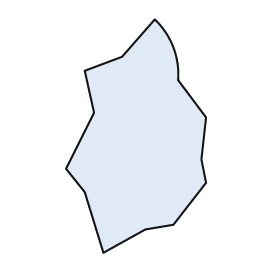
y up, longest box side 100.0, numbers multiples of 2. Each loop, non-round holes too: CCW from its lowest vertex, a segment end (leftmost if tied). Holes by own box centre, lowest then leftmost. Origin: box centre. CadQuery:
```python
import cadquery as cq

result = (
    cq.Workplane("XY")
    .moveTo(-14.0, -50.0)
    .lineTo(4.0, -40.0)
    .lineTo(16.0, -38.0)
    .lineTo(30.0, -20.0)
    .lineTo(28.0, -10.0)
    .lineTo(30.0, 8.0)
    .lineTo(18.0, 24.0)
    .threePointArc((16.0, 38.0), (8.0, 50.0))
    .lineTo(-6.0, 34.0)
    .lineTo(-22.0, 28.0)
    .lineTo(-18.0, 10.0)
    .lineTo(-30.0, -14.0)
    .lineTo(-22.0, -24.0)
    .close()
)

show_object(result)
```